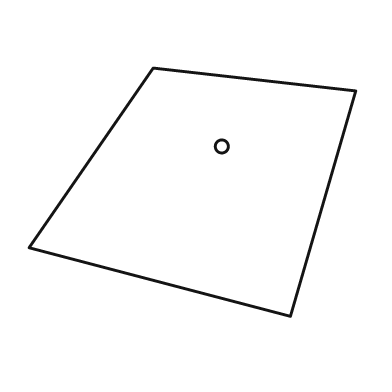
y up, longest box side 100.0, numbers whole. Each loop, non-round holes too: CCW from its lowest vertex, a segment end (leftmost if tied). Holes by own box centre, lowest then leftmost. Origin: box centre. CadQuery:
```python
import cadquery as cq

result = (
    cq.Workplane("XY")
    .moveTo(30.0, -38.0)
    .lineTo(50.0, 31.0)
    .lineTo(-12.0, 38.0)
    .lineTo(-50.0, -17.0)
    .close()
    .moveTo(9.0, 14.0)
    .circle(2.0)
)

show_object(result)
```